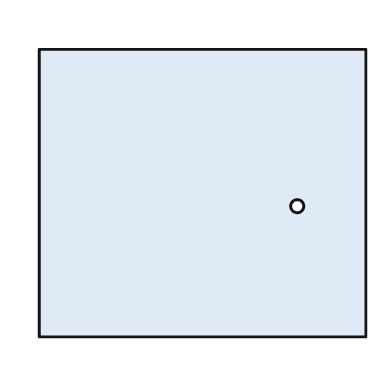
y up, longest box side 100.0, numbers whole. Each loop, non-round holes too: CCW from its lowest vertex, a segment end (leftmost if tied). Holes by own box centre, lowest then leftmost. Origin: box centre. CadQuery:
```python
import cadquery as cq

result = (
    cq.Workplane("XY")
    .moveTo(-50.0, -44.0)
    .lineTo(50.0, -44.0)
    .lineTo(50.0, 44.0)
    .lineTo(-50.0, 44.0)
    .close()
    .moveTo(29.0, -4.0)
    .circle(2.0)
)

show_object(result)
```